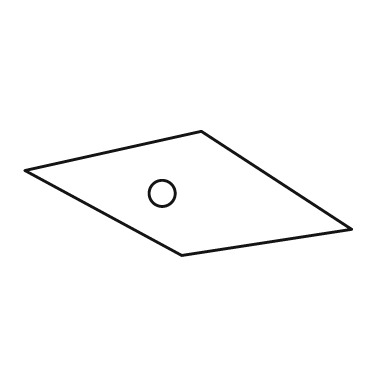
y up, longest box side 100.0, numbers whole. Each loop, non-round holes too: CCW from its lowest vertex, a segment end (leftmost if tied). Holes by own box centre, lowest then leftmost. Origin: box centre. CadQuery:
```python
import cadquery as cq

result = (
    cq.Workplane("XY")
    .moveTo(-2.0, -19.0)
    .lineTo(50.0, -11.0)
    .lineTo(4.0, 19.0)
    .lineTo(-50.0, 7.0)
    .close()
    .moveTo(-8.0, 0.0)
    .circle(4.0)
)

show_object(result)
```